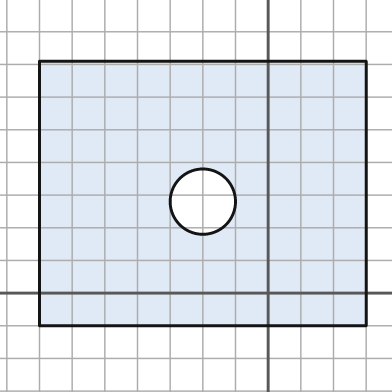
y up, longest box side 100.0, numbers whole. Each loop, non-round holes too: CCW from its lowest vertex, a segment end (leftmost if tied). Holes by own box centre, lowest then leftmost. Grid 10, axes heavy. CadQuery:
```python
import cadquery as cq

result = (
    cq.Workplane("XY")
    .moveTo(-70.0, -10.0)
    .lineTo(30.0, -10.0)
    .lineTo(30.0, 71.0)
    .lineTo(-70.0, 71.0)
    .close()
    .moveTo(-20.0, 28.0)
    .circle(10.0)
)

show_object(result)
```